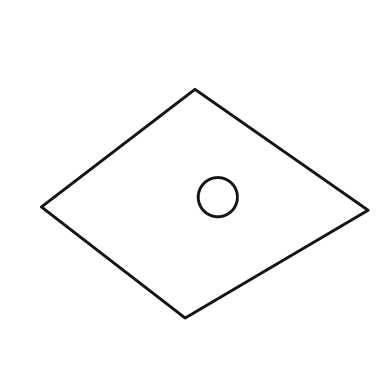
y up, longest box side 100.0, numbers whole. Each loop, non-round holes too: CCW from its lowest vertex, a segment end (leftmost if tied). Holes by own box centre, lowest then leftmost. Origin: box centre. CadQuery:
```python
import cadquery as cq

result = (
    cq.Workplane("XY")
    .moveTo(-6.0, -35.0)
    .lineTo(50.0, -2.0)
    .lineTo(-3.0, 35.0)
    .lineTo(-50.0, -1.0)
    .close()
    .moveTo(4.0, 2.0)
    .circle(6.0)
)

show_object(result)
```